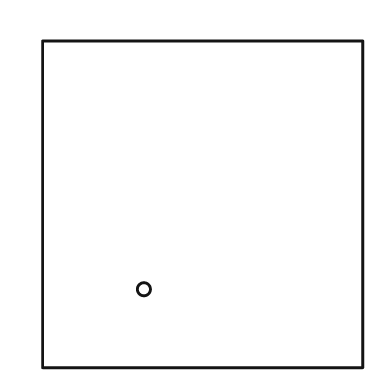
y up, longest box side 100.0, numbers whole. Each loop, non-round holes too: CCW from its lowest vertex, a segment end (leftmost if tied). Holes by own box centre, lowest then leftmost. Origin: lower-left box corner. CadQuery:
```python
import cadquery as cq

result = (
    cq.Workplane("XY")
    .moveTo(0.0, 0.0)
    .lineTo(98.0, 0.0)
    .lineTo(98.0, 100.0)
    .lineTo(0.0, 100.0)
    .close()
    .moveTo(31.0, 24.0)
    .circle(2.0)
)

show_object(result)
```